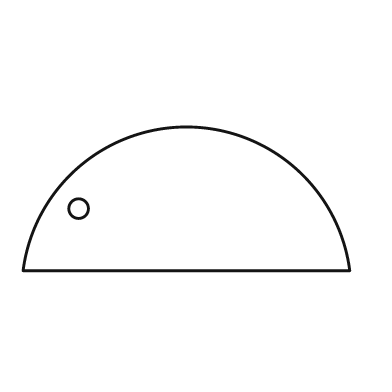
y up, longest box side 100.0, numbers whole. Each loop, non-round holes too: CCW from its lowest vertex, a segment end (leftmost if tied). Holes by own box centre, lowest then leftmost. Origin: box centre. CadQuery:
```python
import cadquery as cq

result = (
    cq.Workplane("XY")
    .moveTo(-50.0, -22.0)
    .lineTo(50.0, -22.0)
    .threePointArc((0.0, 22.0), (-50.0, -22.0))
    .close()
    .moveTo(-33.0, -3.0)
    .circle(3.0)
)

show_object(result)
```